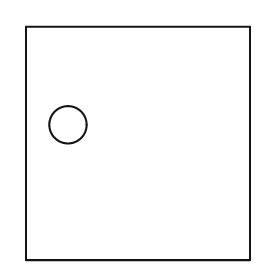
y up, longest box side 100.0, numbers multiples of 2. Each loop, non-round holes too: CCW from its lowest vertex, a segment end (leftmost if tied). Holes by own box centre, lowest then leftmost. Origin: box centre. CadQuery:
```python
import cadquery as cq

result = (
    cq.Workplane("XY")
    .moveTo(-48.0, -50.0)
    .lineTo(48.0, -50.0)
    .lineTo(48.0, 50.0)
    .lineTo(-48.0, 50.0)
    .close()
    .moveTo(-30.0, 8.0)
    .circle(8.0)
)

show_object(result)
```